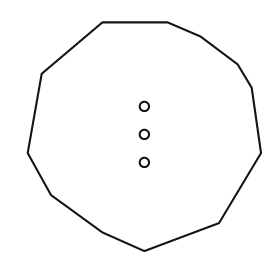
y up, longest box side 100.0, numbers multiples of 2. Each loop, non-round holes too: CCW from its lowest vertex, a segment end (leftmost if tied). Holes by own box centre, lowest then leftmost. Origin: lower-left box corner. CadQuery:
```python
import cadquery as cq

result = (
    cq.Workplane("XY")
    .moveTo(50.0, 0.0)
    .lineTo(82.0, 12.0)
    .lineTo(100.0, 42.0)
    .lineTo(96.0, 70.0)
    .lineTo(90.0, 80.0)
    .lineTo(74.0, 92.0)
    .lineTo(60.0, 98.0)
    .lineTo(32.0, 98.0)
    .lineTo(6.0, 76.0)
    .lineTo(0.0, 42.0)
    .lineTo(10.0, 24.0)
    .lineTo(32.0, 8.0)
    .close()
    .moveTo(50.0, 38.0)
    .circle(2.0)
    .moveTo(50.0, 50.0)
    .circle(2.0)
    .moveTo(50.0, 62.0)
    .circle(2.0)
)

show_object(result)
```